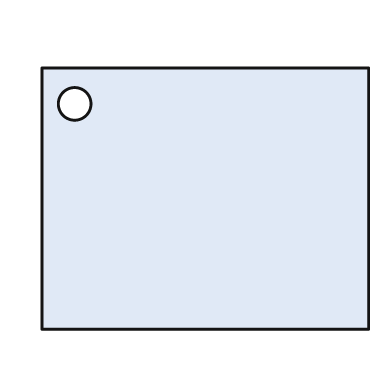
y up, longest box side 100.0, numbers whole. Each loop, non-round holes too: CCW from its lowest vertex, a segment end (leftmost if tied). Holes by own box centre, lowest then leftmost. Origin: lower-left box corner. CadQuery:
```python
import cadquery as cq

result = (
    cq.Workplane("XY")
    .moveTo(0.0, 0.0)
    .lineTo(100.0, 0.0)
    .lineTo(100.0, 80.0)
    .lineTo(0.0, 80.0)
    .close()
    .moveTo(10.0, 69.0)
    .circle(5.0)
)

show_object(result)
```